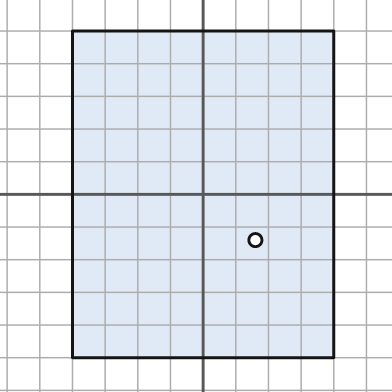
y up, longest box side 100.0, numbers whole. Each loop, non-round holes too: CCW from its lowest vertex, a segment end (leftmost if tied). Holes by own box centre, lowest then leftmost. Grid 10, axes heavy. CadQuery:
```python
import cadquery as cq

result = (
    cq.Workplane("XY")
    .moveTo(-40.0, -50.0)
    .lineTo(40.0, -50.0)
    .lineTo(40.0, 50.0)
    .lineTo(-40.0, 50.0)
    .close()
    .moveTo(16.0, -14.0)
    .circle(2.0)
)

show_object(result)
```